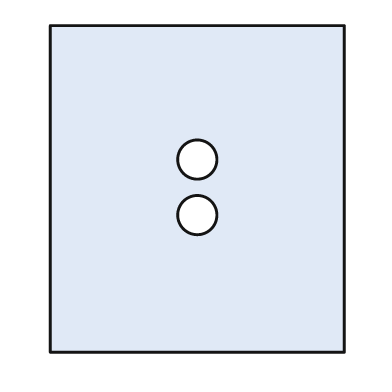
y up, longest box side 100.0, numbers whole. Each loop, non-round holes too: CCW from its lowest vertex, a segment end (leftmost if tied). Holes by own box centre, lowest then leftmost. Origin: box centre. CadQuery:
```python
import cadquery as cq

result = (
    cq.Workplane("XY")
    .moveTo(-45.0, -50.0)
    .lineTo(45.0, -50.0)
    .lineTo(45.0, 50.0)
    .lineTo(-45.0, 50.0)
    .close()
    .moveTo(0.0, -8.0)
    .circle(6.0)
    .moveTo(0.0, 9.0)
    .circle(6.0)
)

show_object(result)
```